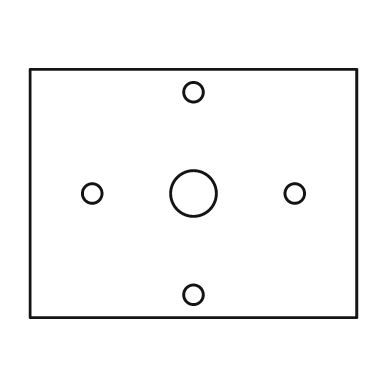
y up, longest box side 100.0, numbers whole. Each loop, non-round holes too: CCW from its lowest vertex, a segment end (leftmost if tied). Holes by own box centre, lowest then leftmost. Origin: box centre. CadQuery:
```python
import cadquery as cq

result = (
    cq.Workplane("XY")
    .moveTo(-50.0, -38.0)
    .lineTo(50.0, -38.0)
    .lineTo(50.0, 38.0)
    .lineTo(-50.0, 38.0)
    .close()
    .moveTo(0.0, -31.0)
    .circle(3.0)
    .moveTo(-31.0, 0.0)
    .circle(3.0)
    .moveTo(0.0, 0.0)
    .circle(7.0)
    .moveTo(31.0, 0.0)
    .circle(3.0)
    .moveTo(0.0, 31.0)
    .circle(3.0)
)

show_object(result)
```